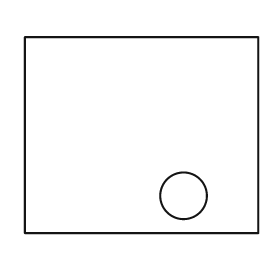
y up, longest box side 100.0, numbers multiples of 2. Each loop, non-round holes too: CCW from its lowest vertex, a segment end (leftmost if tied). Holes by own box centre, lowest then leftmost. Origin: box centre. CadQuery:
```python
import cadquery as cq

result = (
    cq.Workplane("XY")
    .moveTo(-50.0, -42.0)
    .lineTo(50.0, -42.0)
    .lineTo(50.0, 42.0)
    .lineTo(-50.0, 42.0)
    .close()
    .moveTo(18.0, -26.0)
    .circle(10.0)
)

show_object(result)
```